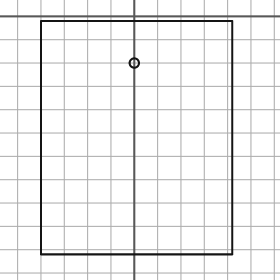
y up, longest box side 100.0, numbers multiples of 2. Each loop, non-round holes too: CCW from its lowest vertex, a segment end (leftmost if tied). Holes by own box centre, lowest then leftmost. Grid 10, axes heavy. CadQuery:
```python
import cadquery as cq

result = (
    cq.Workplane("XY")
    .moveTo(-40.0, -102.0)
    .lineTo(42.0, -102.0)
    .lineTo(42.0, -2.0)
    .lineTo(-40.0, -2.0)
    .close()
    .moveTo(0.0, -20.0)
    .circle(2.0)
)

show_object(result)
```